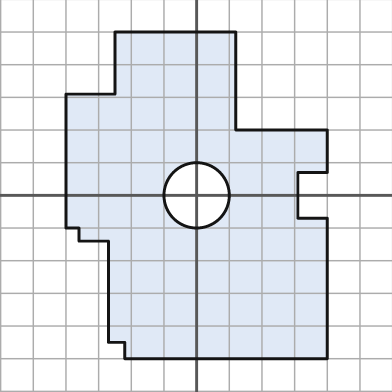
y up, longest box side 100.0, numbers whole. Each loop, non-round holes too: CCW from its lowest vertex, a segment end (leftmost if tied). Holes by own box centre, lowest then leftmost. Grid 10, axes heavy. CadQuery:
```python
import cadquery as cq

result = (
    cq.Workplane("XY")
    .moveTo(-22.0, -50.0)
    .lineTo(40.0, -50.0)
    .lineTo(40.0, -7.0)
    .lineTo(31.0, -7.0)
    .lineTo(31.0, 7.0)
    .lineTo(40.0, 7.0)
    .lineTo(40.0, 20.0)
    .lineTo(12.0, 20.0)
    .lineTo(12.0, 50.0)
    .lineTo(-25.0, 50.0)
    .lineTo(-25.0, 31.0)
    .lineTo(-40.0, 31.0)
    .lineTo(-40.0, -10.0)
    .lineTo(-36.0, -10.0)
    .lineTo(-36.0, -14.0)
    .lineTo(-27.0, -14.0)
    .lineTo(-27.0, -45.0)
    .lineTo(-22.0, -45.0)
    .close()
    .moveTo(0.0, 0.0)
    .circle(10.0)
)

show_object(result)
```